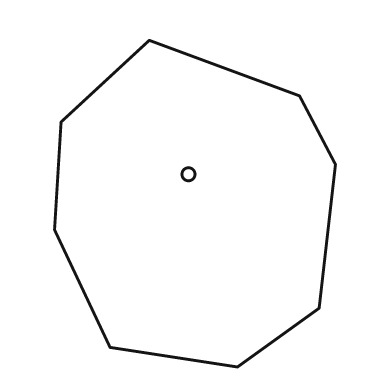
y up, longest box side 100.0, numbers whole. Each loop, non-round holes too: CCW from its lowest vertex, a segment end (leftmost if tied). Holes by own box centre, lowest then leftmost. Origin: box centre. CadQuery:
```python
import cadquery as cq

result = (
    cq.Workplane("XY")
    .moveTo(13.0, -50.0)
    .lineTo(38.0, -32.0)
    .lineTo(43.0, 12.0)
    .lineTo(32.0, 33.0)
    .lineTo(-14.0, 50.0)
    .lineTo(-41.0, 25.0)
    .lineTo(-43.0, -8.0)
    .lineTo(-26.0, -44.0)
    .close()
    .moveTo(-2.0, 9.0)
    .circle(2.0)
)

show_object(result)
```